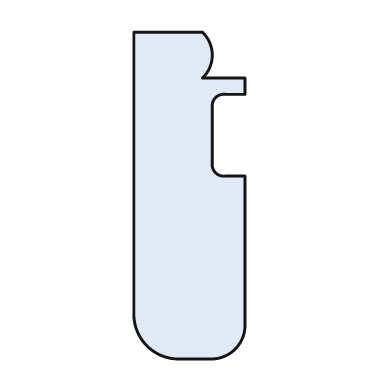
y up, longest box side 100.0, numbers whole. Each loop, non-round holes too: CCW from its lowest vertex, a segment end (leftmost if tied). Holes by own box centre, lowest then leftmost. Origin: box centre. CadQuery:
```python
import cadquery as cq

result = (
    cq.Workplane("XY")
    .moveTo(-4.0, -50.0)
    .lineTo(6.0, -50.0)
    .threePointArc((14.0, -47.0), (17.0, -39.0))
    .lineTo(17.0, 6.0)
    .lineTo(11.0, 6.0)
    .threePointArc((8.0, 7.0), (7.0, 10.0))
    .lineTo(7.0, 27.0)
    .threePointArc((8.0, 30.0), (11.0, 31.0))
    .lineTo(17.0, 31.0)
    .lineTo(17.0, 36.0)
    .lineTo(4.0, 36.0)
    .threePointArc((7.0, 43.0), (4.0, 50.0))
    .lineTo(-17.0, 50.0)
    .lineTo(-17.0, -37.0)
    .threePointArc((-13.0, -46.0), (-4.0, -50.0))
    .close()
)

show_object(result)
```